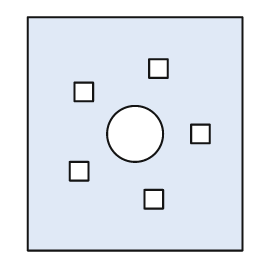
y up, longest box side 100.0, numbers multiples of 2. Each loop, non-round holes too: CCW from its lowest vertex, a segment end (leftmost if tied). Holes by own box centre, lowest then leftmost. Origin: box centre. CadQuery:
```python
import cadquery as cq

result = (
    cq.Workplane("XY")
    .moveTo(-46.0, -50.0)
    .lineTo(46.0, -50.0)
    .lineTo(46.0, 50.0)
    .lineTo(-46.0, 50.0)
    .close()
    .moveTo(4.0, -32.0)
    .lineTo(12.0, -32.0)
    .lineTo(12.0, -24.0)
    .lineTo(4.0, -24.0)
    .close()
    .moveTo(-28.0, -20.0)
    .lineTo(-20.0, -20.0)
    .lineTo(-20.0, -12.0)
    .lineTo(-28.0, -12.0)
    .close()
    .moveTo(0.0, 0.0)
    .circle(12.0)
    .moveTo(24.0, -4.0)
    .lineTo(32.0, -4.0)
    .lineTo(32.0, 4.0)
    .lineTo(24.0, 4.0)
    .close()
    .moveTo(-26.0, 14.0)
    .lineTo(-18.0, 14.0)
    .lineTo(-18.0, 22.0)
    .lineTo(-26.0, 22.0)
    .close()
    .moveTo(6.0, 24.0)
    .lineTo(14.0, 24.0)
    .lineTo(14.0, 32.0)
    .lineTo(6.0, 32.0)
    .close()
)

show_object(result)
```